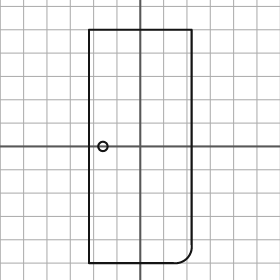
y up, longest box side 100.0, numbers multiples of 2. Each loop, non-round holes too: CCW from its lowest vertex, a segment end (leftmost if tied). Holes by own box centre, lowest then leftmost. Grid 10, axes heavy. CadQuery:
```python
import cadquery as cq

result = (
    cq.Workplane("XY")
    .moveTo(-22.0, -50.0)
    .lineTo(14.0, -50.0)
    .threePointArc((20.0, -48.0), (22.0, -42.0))
    .lineTo(22.0, 50.0)
    .lineTo(-22.0, 50.0)
    .close()
    .moveTo(-16.0, 0.0)
    .circle(2.0)
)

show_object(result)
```